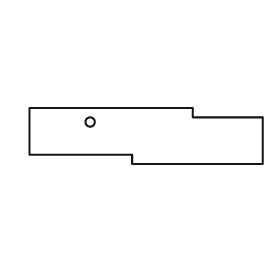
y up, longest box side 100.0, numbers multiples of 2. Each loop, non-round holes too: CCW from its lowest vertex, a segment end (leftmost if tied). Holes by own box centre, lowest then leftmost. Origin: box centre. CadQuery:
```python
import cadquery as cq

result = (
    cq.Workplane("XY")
    .moveTo(-6.0, -12.0)
    .lineTo(50.0, -12.0)
    .lineTo(50.0, 8.0)
    .lineTo(20.0, 8.0)
    .lineTo(20.0, 12.0)
    .lineTo(-50.0, 12.0)
    .lineTo(-50.0, -8.0)
    .lineTo(-6.0, -8.0)
    .close()
    .moveTo(-24.0, 6.0)
    .circle(2.0)
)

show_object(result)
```